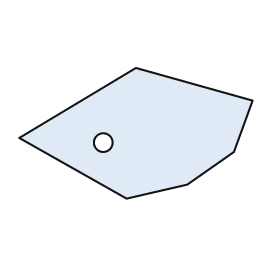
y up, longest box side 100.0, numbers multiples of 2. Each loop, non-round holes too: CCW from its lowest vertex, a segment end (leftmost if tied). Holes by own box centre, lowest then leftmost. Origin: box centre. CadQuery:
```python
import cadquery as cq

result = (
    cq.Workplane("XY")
    .moveTo(-4.0, -28.0)
    .lineTo(22.0, -22.0)
    .lineTo(42.0, -8.0)
    .lineTo(50.0, 14.0)
    .lineTo(0.0, 28.0)
    .lineTo(-50.0, -2.0)
    .close()
    .moveTo(-14.0, -4.0)
    .circle(4.0)
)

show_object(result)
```